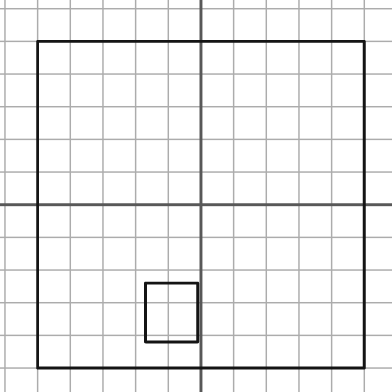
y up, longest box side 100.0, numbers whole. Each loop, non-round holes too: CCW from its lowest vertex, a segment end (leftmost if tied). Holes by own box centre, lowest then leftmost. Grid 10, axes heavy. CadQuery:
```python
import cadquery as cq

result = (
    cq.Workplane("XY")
    .moveTo(-50.0, -50.0)
    .lineTo(50.0, -50.0)
    .lineTo(50.0, 50.0)
    .lineTo(-50.0, 50.0)
    .close()
    .moveTo(-17.0, -42.0)
    .lineTo(-1.0, -42.0)
    .lineTo(-1.0, -24.0)
    .lineTo(-17.0, -24.0)
    .close()
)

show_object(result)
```